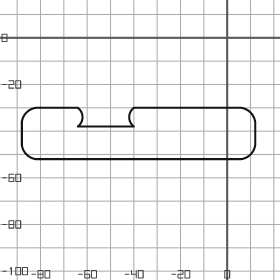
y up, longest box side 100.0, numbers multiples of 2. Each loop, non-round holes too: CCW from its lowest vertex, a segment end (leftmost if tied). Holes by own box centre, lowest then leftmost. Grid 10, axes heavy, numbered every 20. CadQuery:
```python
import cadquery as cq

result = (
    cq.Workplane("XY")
    .moveTo(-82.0, -52.0)
    .lineTo(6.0, -52.0)
    .threePointArc((10.0, -50.0), (12.0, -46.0))
    .lineTo(12.0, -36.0)
    .threePointArc((10.0, -32.0), (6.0, -30.0))
    .lineTo(-40.0, -30.0)
    .threePointArc((-42.0, -34.0), (-40.0, -38.0))
    .lineTo(-64.0, -38.0)
    .threePointArc((-62.0, -34.0), (-64.0, -30.0))
    .lineTo(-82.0, -30.0)
    .threePointArc((-86.0, -32.0), (-88.0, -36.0))
    .lineTo(-88.0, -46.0)
    .threePointArc((-86.0, -50.0), (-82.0, -52.0))
    .close()
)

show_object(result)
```